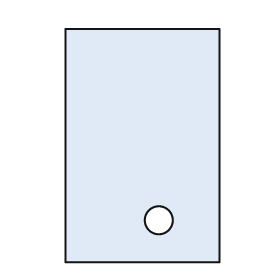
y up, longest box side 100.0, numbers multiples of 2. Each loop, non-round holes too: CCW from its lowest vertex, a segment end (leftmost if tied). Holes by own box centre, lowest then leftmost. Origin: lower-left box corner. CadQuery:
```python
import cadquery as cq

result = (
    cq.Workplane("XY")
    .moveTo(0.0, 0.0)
    .lineTo(66.0, 0.0)
    .lineTo(66.0, 100.0)
    .lineTo(0.0, 100.0)
    .close()
    .moveTo(40.0, 18.0)
    .circle(6.0)
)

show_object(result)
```